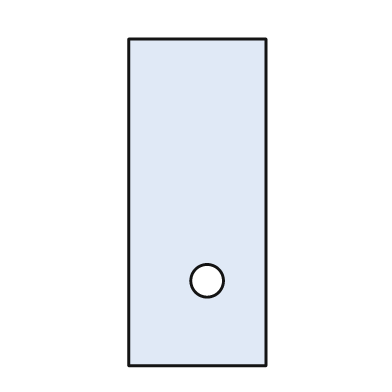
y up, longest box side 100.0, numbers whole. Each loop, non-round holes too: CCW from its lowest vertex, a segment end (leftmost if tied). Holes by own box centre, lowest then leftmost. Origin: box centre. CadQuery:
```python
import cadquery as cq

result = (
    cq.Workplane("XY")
    .moveTo(-21.0, -50.0)
    .lineTo(21.0, -50.0)
    .lineTo(21.0, 50.0)
    .lineTo(-21.0, 50.0)
    .close()
    .moveTo(3.0, -24.0)
    .circle(5.0)
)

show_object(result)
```